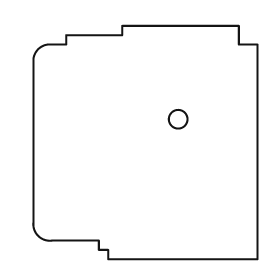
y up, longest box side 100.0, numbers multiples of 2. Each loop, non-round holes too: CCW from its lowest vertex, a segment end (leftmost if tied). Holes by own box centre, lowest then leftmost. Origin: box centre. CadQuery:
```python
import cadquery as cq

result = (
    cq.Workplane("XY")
    .moveTo(-16.0, -50.0)
    .lineTo(48.0, -50.0)
    .lineTo(48.0, 42.0)
    .lineTo(40.0, 42.0)
    .lineTo(40.0, 50.0)
    .lineTo(-10.0, 50.0)
    .lineTo(-10.0, 46.0)
    .lineTo(-34.0, 46.0)
    .lineTo(-34.0, 42.0)
    .lineTo(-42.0, 42.0)
    .threePointArc((-46.0, 40.0), (-48.0, 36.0))
    .lineTo(-48.0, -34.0)
    .threePointArc((-46.0, -40.0), (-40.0, -42.0))
    .lineTo(-20.0, -42.0)
    .lineTo(-20.0, -46.0)
    .lineTo(-16.0, -46.0)
    .close()
    .moveTo(14.0, 10.0)
    .circle(4.0)
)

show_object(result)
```